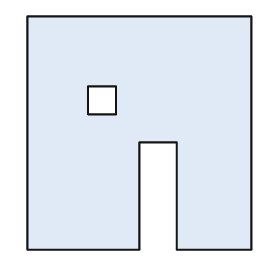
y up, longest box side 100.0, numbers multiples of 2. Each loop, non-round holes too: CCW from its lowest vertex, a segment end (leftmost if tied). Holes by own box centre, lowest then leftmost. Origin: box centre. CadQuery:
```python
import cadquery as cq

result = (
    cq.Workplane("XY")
    .moveTo(-48.0, -50.0)
    .lineTo(0.0, -50.0)
    .lineTo(0.0, -4.0)
    .lineTo(16.0, -4.0)
    .lineTo(16.0, -50.0)
    .lineTo(48.0, -50.0)
    .lineTo(48.0, 50.0)
    .lineTo(-48.0, 50.0)
    .close()
    .moveTo(-22.0, 8.0)
    .lineTo(-10.0, 8.0)
    .lineTo(-10.0, 20.0)
    .lineTo(-22.0, 20.0)
    .close()
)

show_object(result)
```